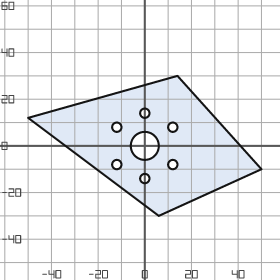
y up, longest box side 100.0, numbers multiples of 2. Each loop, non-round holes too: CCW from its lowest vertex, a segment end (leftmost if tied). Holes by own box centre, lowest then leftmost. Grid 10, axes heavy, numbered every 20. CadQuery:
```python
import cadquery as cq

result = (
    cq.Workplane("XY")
    .moveTo(6.0, -30.0)
    .lineTo(50.0, -10.0)
    .lineTo(14.0, 30.0)
    .lineTo(-50.0, 12.0)
    .close()
    .moveTo(0.0, -14.0)
    .circle(2.0)
    .moveTo(-12.0, -8.0)
    .circle(2.0)
    .moveTo(12.0, -8.0)
    .circle(2.0)
    .moveTo(0.0, 0.0)
    .circle(6.0)
    .moveTo(-12.0, 8.0)
    .circle(2.0)
    .moveTo(12.0, 8.0)
    .circle(2.0)
    .moveTo(0.0, 14.0)
    .circle(2.0)
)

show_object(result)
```